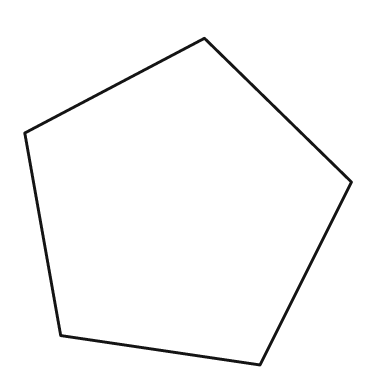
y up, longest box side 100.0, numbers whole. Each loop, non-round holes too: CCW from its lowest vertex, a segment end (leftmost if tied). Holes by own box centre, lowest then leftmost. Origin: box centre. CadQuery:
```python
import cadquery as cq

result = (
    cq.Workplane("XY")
    .moveTo(22.0, -50.0)
    .lineTo(50.0, 6.0)
    .lineTo(5.0, 50.0)
    .lineTo(-50.0, 21.0)
    .lineTo(-39.0, -41.0)
    .close()
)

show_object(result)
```